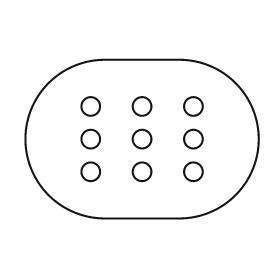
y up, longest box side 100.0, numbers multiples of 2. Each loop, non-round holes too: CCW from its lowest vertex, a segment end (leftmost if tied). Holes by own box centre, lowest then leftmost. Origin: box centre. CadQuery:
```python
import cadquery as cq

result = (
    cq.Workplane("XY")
    .moveTo(-16.0, -34.0)
    .lineTo(16.0, -34.0)
    .threePointArc((50.0, 0.0), (16.0, 34.0))
    .lineTo(-16.0, 34.0)
    .threePointArc((-50.0, 0.0), (-16.0, -34.0))
    .close()
    .moveTo(-22.0, -14.0)
    .circle(4.0)
    .moveTo(0.0, -14.0)
    .circle(4.0)
    .moveTo(22.0, -14.0)
    .circle(4.0)
    .moveTo(-22.0, 0.0)
    .circle(4.0)
    .moveTo(0.0, 0.0)
    .circle(4.0)
    .moveTo(22.0, 0.0)
    .circle(4.0)
    .moveTo(-22.0, 14.0)
    .circle(4.0)
    .moveTo(0.0, 14.0)
    .circle(4.0)
    .moveTo(22.0, 14.0)
    .circle(4.0)
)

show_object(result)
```